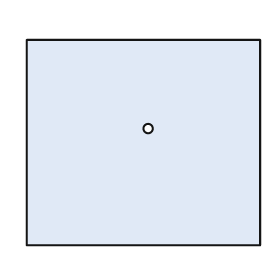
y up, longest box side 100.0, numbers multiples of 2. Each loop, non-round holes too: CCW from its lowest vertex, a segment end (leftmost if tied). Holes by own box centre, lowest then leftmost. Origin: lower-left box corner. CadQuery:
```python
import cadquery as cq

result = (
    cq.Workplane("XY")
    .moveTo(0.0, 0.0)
    .lineTo(100.0, 0.0)
    .lineTo(100.0, 88.0)
    .lineTo(0.0, 88.0)
    .close()
    .moveTo(52.0, 50.0)
    .circle(2.0)
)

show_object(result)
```